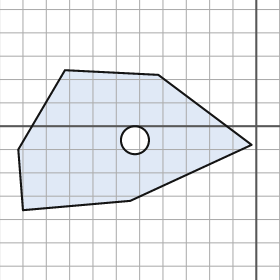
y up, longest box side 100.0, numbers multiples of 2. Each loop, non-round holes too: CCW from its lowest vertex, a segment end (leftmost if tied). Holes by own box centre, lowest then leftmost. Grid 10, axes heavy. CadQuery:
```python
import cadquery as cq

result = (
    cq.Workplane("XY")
    .moveTo(-100.0, -36.0)
    .lineTo(-54.0, -32.0)
    .lineTo(-2.0, -8.0)
    .lineTo(-42.0, 22.0)
    .lineTo(-82.0, 24.0)
    .lineTo(-102.0, -10.0)
    .close()
    .moveTo(-52.0, -6.0)
    .circle(6.0)
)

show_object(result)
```